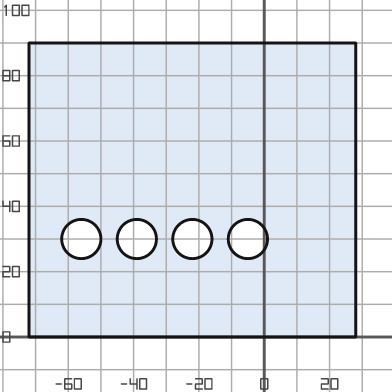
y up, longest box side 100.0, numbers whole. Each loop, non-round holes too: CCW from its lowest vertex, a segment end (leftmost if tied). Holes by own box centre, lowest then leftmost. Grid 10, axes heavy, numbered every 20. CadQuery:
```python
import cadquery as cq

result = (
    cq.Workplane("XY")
    .moveTo(-72.0, 0.0)
    .lineTo(28.0, 0.0)
    .lineTo(28.0, 90.0)
    .lineTo(-72.0, 90.0)
    .close()
    .moveTo(-56.0, 30.0)
    .circle(6.0)
    .moveTo(-39.0, 30.0)
    .circle(6.0)
    .moveTo(-22.0, 30.0)
    .circle(6.0)
    .moveTo(-5.0, 30.0)
    .circle(6.0)
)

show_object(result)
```